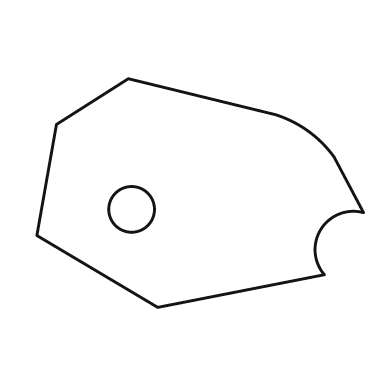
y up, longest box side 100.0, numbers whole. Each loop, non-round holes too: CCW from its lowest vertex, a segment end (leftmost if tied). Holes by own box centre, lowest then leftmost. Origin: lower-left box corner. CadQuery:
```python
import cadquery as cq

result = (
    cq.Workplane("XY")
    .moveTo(37.0, 0.0)
    .lineTo(88.0, 10.0)
    .threePointArc((87.0, 24.0), (100.0, 29.0))
    .lineTo(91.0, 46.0)
    .threePointArc((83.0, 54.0), (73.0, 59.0))
    .lineTo(28.0, 70.0)
    .lineTo(6.0, 56.0)
    .lineTo(0.0, 22.0)
    .close()
    .moveTo(29.0, 30.0)
    .circle(7.0)
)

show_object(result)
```